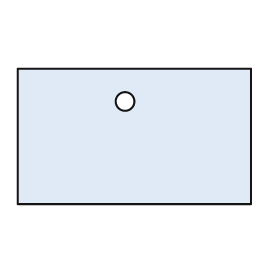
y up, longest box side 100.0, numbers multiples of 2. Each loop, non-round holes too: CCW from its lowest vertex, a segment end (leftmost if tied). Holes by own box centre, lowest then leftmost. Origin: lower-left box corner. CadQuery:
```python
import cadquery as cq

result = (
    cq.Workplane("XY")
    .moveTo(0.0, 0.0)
    .lineTo(100.0, 0.0)
    .lineTo(100.0, 58.0)
    .lineTo(0.0, 58.0)
    .close()
    .moveTo(46.0, 44.0)
    .circle(4.0)
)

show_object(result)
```